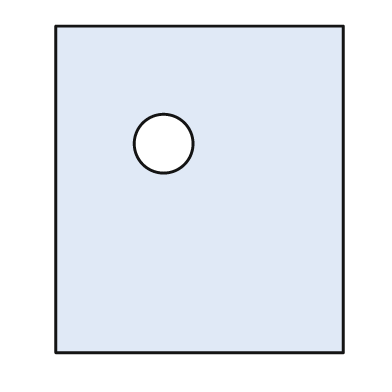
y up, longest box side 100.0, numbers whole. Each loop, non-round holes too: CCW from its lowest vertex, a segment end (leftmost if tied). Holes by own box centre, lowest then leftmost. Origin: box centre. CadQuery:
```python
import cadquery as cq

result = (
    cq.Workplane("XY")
    .moveTo(-44.0, -50.0)
    .lineTo(44.0, -50.0)
    .lineTo(44.0, 50.0)
    .lineTo(-44.0, 50.0)
    .close()
    .moveTo(-11.0, 14.0)
    .circle(9.0)
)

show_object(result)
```